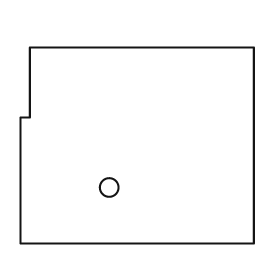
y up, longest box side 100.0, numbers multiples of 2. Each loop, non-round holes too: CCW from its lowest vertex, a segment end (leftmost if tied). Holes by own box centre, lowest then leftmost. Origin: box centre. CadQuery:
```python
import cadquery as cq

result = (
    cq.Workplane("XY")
    .moveTo(-50.0, -42.0)
    .lineTo(50.0, -42.0)
    .lineTo(50.0, 42.0)
    .lineTo(-46.0, 42.0)
    .lineTo(-46.0, 12.0)
    .lineTo(-50.0, 12.0)
    .close()
    .moveTo(-12.0, -18.0)
    .circle(4.0)
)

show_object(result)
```